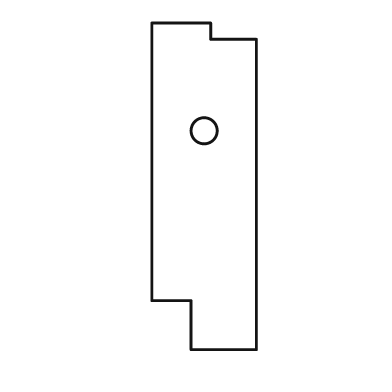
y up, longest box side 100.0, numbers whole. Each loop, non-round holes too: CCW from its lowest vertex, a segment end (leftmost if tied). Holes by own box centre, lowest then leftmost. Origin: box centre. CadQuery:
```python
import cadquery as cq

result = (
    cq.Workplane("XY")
    .moveTo(-4.0, -50.0)
    .lineTo(16.0, -50.0)
    .lineTo(16.0, 45.0)
    .lineTo(2.0, 45.0)
    .lineTo(2.0, 50.0)
    .lineTo(-16.0, 50.0)
    .lineTo(-16.0, -35.0)
    .lineTo(-4.0, -35.0)
    .close()
    .moveTo(0.0, 17.0)
    .circle(4.0)
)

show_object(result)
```